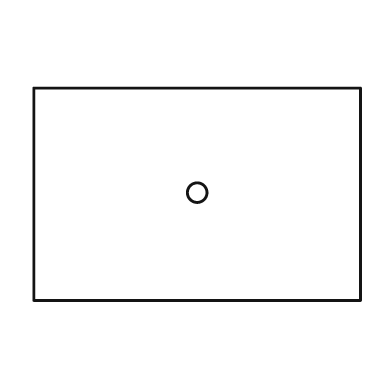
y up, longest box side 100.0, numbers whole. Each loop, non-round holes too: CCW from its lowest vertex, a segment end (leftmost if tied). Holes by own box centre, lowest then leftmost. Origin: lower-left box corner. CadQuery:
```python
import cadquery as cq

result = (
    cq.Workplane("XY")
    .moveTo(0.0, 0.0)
    .lineTo(100.0, 0.0)
    .lineTo(100.0, 65.0)
    .lineTo(0.0, 65.0)
    .close()
    .moveTo(50.0, 33.0)
    .circle(3.0)
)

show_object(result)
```